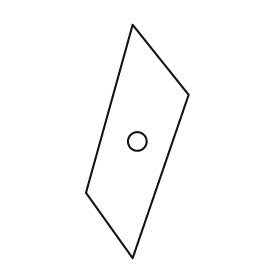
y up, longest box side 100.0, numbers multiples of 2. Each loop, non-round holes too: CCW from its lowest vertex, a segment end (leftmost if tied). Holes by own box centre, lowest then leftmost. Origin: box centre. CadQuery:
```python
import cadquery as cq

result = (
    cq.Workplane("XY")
    .moveTo(-2.0, -50.0)
    .lineTo(22.0, 20.0)
    .lineTo(-2.0, 50.0)
    .lineTo(-22.0, -22.0)
    .close()
    .moveTo(0.0, 0.0)
    .circle(4.0)
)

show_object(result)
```